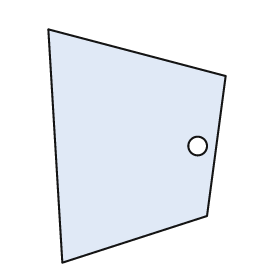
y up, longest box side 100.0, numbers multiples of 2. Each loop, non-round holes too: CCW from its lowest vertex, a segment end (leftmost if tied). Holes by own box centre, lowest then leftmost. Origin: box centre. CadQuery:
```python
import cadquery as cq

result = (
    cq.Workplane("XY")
    .moveTo(-32.0, -50.0)
    .lineTo(30.0, -30.0)
    .lineTo(38.0, 30.0)
    .lineTo(-38.0, 50.0)
    .close()
    .moveTo(26.0, 0.0)
    .circle(4.0)
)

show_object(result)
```